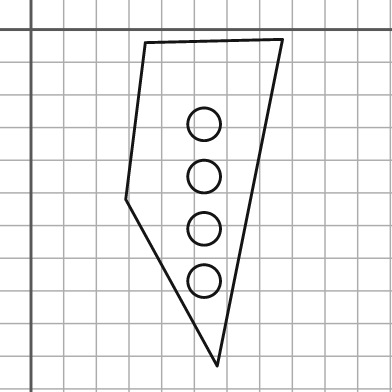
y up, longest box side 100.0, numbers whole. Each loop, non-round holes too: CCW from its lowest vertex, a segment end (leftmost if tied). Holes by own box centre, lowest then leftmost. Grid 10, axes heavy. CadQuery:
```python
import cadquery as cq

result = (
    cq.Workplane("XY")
    .moveTo(57.0, -103.0)
    .lineTo(77.0, -3.0)
    .lineTo(35.0, -4.0)
    .lineTo(29.0, -52.0)
    .close()
    .moveTo(53.0, -77.0)
    .circle(5.0)
    .moveTo(53.0, -61.0)
    .circle(5.0)
    .moveTo(53.0, -45.0)
    .circle(5.0)
    .moveTo(53.0, -29.0)
    .circle(5.0)
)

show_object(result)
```